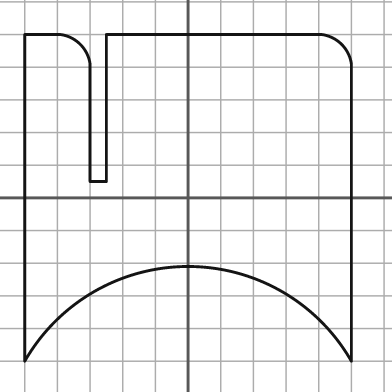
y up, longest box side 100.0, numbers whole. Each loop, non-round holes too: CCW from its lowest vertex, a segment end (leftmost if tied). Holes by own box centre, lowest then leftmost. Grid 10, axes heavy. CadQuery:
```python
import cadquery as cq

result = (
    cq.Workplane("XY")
    .moveTo(-50.0, -50.0)
    .threePointArc((0.0, -21.0), (50.0, -50.0))
    .lineTo(50.0, 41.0)
    .threePointArc((47.0, 47.0), (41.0, 50.0))
    .lineTo(-25.0, 50.0)
    .lineTo(-25.0, 5.0)
    .lineTo(-30.0, 5.0)
    .lineTo(-30.0, 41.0)
    .threePointArc((-33.0, 47.0), (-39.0, 50.0))
    .lineTo(-50.0, 50.0)
    .close()
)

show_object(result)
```